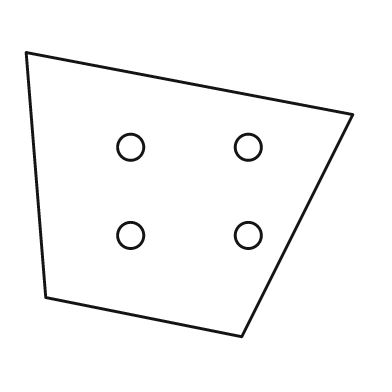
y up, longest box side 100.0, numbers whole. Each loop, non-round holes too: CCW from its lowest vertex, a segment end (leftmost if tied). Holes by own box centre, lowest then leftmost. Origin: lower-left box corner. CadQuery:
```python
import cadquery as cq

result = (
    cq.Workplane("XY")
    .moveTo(66.0, 0.0)
    .lineTo(100.0, 68.0)
    .lineTo(0.0, 87.0)
    .lineTo(6.0, 12.0)
    .close()
    .moveTo(32.0, 31.0)
    .circle(4.0)
    .moveTo(68.0, 31.0)
    .circle(4.0)
    .moveTo(32.0, 58.0)
    .circle(4.0)
    .moveTo(68.0, 58.0)
    .circle(4.0)
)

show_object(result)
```